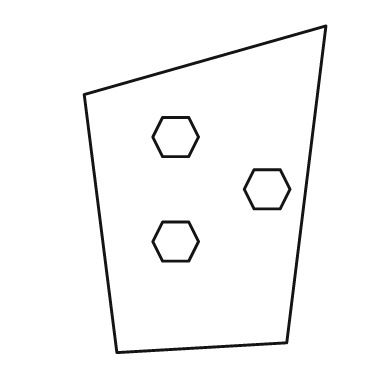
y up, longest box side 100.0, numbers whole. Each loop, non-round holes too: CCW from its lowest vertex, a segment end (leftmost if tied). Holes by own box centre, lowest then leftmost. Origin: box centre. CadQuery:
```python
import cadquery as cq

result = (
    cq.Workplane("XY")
    .moveTo(-27.0, -50.0)
    .lineTo(25.0, -47.0)
    .lineTo(37.0, 50.0)
    .lineTo(-37.0, 29.0)
    .close()
    .moveTo(-13.0, -22.0)
    .lineTo(-5.0, -22.0)
    .lineTo(-2.0, -16.0)
    .lineTo(-5.0, -10.0)
    .lineTo(-13.0, -10.0)
    .lineTo(-16.0, -16.0)
    .close()
    .moveTo(15.0, -6.0)
    .lineTo(23.0, -6.0)
    .lineTo(26.0, 0.0)
    .lineTo(23.0, 6.0)
    .lineTo(15.0, 6.0)
    .lineTo(12.0, 0.0)
    .close()
    .moveTo(-13.0, 10.0)
    .lineTo(-5.0, 10.0)
    .lineTo(-2.0, 16.0)
    .lineTo(-5.0, 22.0)
    .lineTo(-13.0, 22.0)
    .lineTo(-16.0, 16.0)
    .close()
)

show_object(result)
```